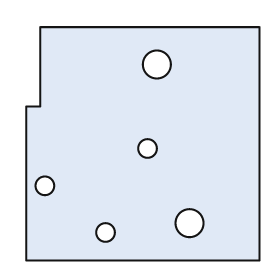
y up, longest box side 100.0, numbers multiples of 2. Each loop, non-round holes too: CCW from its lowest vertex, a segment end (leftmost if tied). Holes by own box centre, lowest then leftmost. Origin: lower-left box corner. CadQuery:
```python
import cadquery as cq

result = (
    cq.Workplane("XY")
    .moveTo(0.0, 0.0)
    .lineTo(100.0, 0.0)
    .lineTo(100.0, 100.0)
    .lineTo(6.0, 100.0)
    .lineTo(6.0, 66.0)
    .lineTo(0.0, 66.0)
    .close()
    .moveTo(34.0, 12.0)
    .circle(4.0)
    .moveTo(70.0, 16.0)
    .circle(6.0)
    .moveTo(8.0, 32.0)
    .circle(4.0)
    .moveTo(52.0, 48.0)
    .circle(4.0)
    .moveTo(56.0, 84.0)
    .circle(6.0)
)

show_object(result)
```